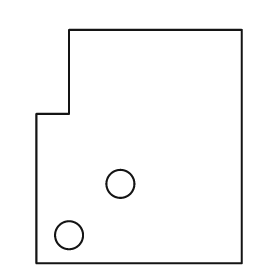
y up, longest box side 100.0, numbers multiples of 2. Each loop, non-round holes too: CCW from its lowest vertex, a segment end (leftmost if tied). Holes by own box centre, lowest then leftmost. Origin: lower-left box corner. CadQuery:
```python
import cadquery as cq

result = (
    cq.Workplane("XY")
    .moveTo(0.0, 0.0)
    .lineTo(88.0, 0.0)
    .lineTo(88.0, 100.0)
    .lineTo(14.0, 100.0)
    .lineTo(14.0, 64.0)
    .lineTo(0.0, 64.0)
    .close()
    .moveTo(14.0, 12.0)
    .circle(6.0)
    .moveTo(36.0, 34.0)
    .circle(6.0)
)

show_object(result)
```